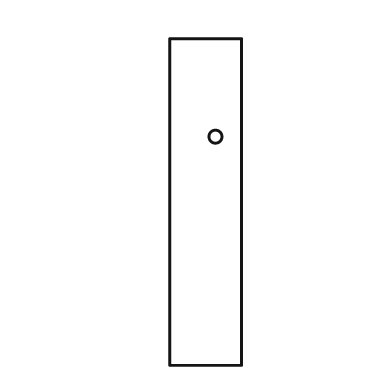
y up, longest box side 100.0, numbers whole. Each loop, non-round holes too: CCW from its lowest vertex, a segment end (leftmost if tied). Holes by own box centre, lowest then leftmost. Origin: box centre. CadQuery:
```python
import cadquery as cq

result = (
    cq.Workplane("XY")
    .moveTo(-11.0, -50.0)
    .lineTo(11.0, -50.0)
    .lineTo(11.0, 50.0)
    .lineTo(-11.0, 50.0)
    .close()
    .moveTo(3.0, 20.0)
    .circle(2.0)
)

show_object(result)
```